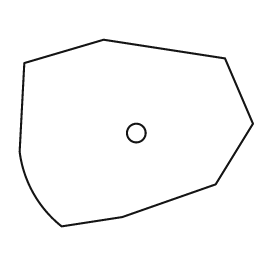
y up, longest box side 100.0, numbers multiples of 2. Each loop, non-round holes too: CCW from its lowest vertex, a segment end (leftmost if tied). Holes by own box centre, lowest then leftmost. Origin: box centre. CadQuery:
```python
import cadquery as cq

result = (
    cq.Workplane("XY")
    .moveTo(-32.0, -40.0)
    .lineTo(-6.0, -36.0)
    .lineTo(34.0, -22.0)
    .lineTo(50.0, 4.0)
    .lineTo(38.0, 32.0)
    .lineTo(-14.0, 40.0)
    .lineTo(-48.0, 30.0)
    .lineTo(-50.0, -8.0)
    .threePointArc((-44.0, -26.0), (-32.0, -40.0))
    .close()
    .moveTo(0.0, 0.0)
    .circle(4.0)
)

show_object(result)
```